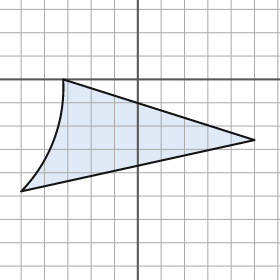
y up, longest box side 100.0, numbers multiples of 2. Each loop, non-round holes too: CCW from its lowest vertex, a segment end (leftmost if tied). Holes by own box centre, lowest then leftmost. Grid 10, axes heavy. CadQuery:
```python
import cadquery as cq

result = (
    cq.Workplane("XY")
    .moveTo(-50.0, -48.0)
    .lineTo(50.0, -26.0)
    .lineTo(-32.0, 0.0)
    .threePointArc((-36.0, -26.0), (-50.0, -48.0))
    .close()
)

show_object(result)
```